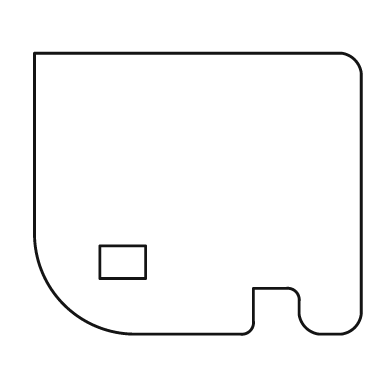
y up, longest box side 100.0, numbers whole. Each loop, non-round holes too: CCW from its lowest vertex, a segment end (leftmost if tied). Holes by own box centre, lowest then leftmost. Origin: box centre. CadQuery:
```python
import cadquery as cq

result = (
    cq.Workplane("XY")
    .moveTo(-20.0, -43.0)
    .lineTo(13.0, -43.0)
    .threePointArc((16.0, -42.0), (17.0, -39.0))
    .lineTo(17.0, -29.0)
    .lineTo(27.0, -29.0)
    .threePointArc((30.0, -30.0), (31.0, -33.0))
    .lineTo(31.0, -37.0)
    .threePointArc((33.0, -41.0), (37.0, -43.0))
    .lineTo(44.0, -43.0)
    .threePointArc((48.0, -41.0), (50.0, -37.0))
    .lineTo(50.0, 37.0)
    .threePointArc((48.0, 41.0), (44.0, 43.0))
    .lineTo(-50.0, 43.0)
    .lineTo(-50.0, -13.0)
    .threePointArc((-41.0, -34.0), (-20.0, -43.0))
    .close()
    .moveTo(-30.0, -26.0)
    .lineTo(-16.0, -26.0)
    .lineTo(-16.0, -16.0)
    .lineTo(-30.0, -16.0)
    .close()
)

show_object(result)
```